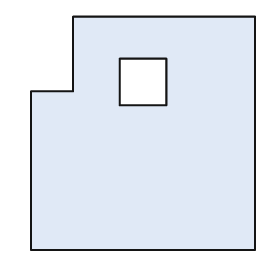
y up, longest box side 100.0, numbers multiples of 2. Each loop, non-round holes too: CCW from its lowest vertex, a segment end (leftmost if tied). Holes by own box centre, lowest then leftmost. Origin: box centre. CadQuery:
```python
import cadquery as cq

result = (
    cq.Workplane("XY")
    .moveTo(-48.0, -50.0)
    .lineTo(48.0, -50.0)
    .lineTo(48.0, 50.0)
    .lineTo(-30.0, 50.0)
    .lineTo(-30.0, 18.0)
    .lineTo(-48.0, 18.0)
    .close()
    .moveTo(-10.0, 12.0)
    .lineTo(10.0, 12.0)
    .lineTo(10.0, 32.0)
    .lineTo(-10.0, 32.0)
    .close()
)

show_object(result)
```